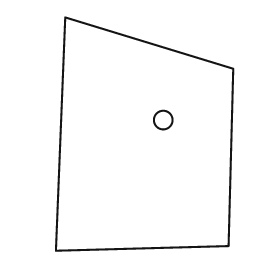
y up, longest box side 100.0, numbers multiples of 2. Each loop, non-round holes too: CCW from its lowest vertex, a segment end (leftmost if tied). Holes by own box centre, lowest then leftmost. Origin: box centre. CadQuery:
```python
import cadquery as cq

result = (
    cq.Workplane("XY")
    .moveTo(-38.0, -50.0)
    .lineTo(36.0, -48.0)
    .lineTo(38.0, 28.0)
    .lineTo(-34.0, 50.0)
    .close()
    .moveTo(8.0, 6.0)
    .circle(4.0)
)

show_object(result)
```